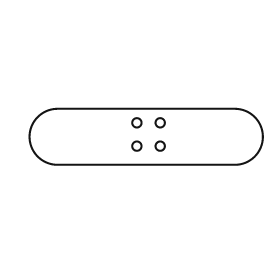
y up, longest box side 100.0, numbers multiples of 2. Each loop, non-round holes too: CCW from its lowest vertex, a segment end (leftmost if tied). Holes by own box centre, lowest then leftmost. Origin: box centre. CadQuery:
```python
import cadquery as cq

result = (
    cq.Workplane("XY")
    .moveTo(-38.0, -12.0)
    .lineTo(38.0, -12.0)
    .threePointArc((50.0, 0.0), (38.0, 12.0))
    .lineTo(-38.0, 12.0)
    .threePointArc((-50.0, 0.0), (-38.0, -12.0))
    .close()
    .moveTo(-4.0, -4.0)
    .circle(2.0)
    .moveTo(6.0, -4.0)
    .circle(2.0)
    .moveTo(-4.0, 6.0)
    .circle(2.0)
    .moveTo(6.0, 6.0)
    .circle(2.0)
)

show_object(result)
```